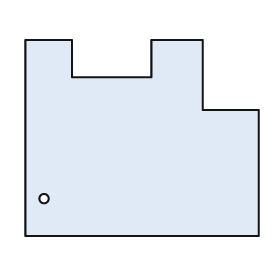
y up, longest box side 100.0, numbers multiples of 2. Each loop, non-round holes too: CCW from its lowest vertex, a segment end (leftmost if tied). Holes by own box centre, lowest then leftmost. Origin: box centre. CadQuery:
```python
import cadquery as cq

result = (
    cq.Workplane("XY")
    .moveTo(-50.0, -42.0)
    .lineTo(50.0, -42.0)
    .lineTo(50.0, 12.0)
    .lineTo(26.0, 12.0)
    .lineTo(26.0, 42.0)
    .lineTo(4.0, 42.0)
    .lineTo(4.0, 26.0)
    .lineTo(-30.0, 26.0)
    .lineTo(-30.0, 42.0)
    .lineTo(-50.0, 42.0)
    .close()
    .moveTo(-42.0, -26.0)
    .circle(2.0)
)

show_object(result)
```